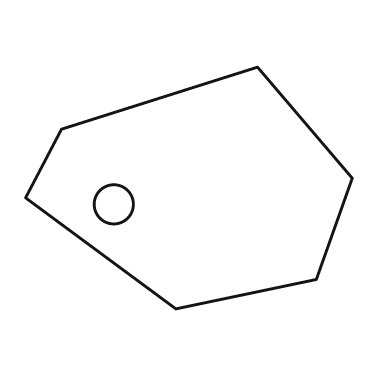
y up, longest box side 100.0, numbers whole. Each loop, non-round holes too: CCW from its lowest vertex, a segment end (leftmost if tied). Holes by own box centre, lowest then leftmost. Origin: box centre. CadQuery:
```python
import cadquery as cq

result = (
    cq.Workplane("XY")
    .moveTo(-4.0, -37.0)
    .lineTo(39.0, -28.0)
    .lineTo(50.0, 3.0)
    .lineTo(21.0, 37.0)
    .lineTo(-39.0, 18.0)
    .lineTo(-50.0, -3.0)
    .close()
    .moveTo(-23.0, -5.0)
    .circle(6.0)
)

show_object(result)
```